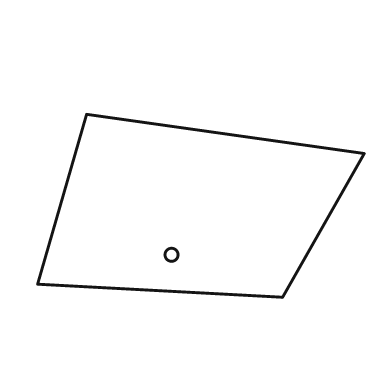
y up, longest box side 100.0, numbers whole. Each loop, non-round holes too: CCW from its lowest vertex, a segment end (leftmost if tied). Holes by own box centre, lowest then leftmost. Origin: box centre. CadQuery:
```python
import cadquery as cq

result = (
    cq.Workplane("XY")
    .moveTo(25.0, -28.0)
    .lineTo(50.0, 16.0)
    .lineTo(-35.0, 28.0)
    .lineTo(-50.0, -24.0)
    .close()
    .moveTo(-9.0, -15.0)
    .circle(2.0)
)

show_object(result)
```